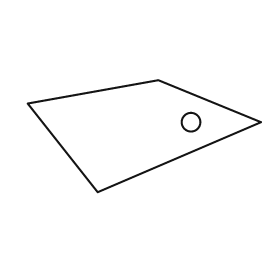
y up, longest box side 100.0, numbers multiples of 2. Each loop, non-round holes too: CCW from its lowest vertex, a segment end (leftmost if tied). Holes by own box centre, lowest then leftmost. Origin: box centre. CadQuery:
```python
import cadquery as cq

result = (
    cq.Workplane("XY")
    .moveTo(-20.0, -24.0)
    .lineTo(50.0, 6.0)
    .lineTo(6.0, 24.0)
    .lineTo(-50.0, 14.0)
    .close()
    .moveTo(20.0, 6.0)
    .circle(4.0)
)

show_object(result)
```